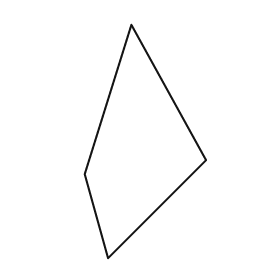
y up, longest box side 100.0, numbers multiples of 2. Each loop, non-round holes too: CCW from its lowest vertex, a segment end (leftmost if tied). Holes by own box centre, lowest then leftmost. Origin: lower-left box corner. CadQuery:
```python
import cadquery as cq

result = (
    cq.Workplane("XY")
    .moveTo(10.0, 0.0)
    .lineTo(52.0, 42.0)
    .lineTo(20.0, 100.0)
    .lineTo(0.0, 36.0)
    .close()
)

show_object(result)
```